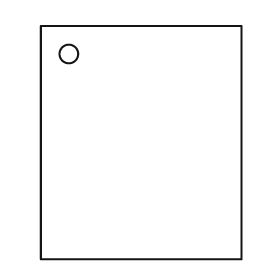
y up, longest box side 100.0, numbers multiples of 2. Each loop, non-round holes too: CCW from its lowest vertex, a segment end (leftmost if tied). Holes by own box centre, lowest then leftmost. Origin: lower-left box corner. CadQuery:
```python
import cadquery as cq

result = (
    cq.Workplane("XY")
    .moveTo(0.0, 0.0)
    .lineTo(86.0, 0.0)
    .lineTo(86.0, 100.0)
    .lineTo(0.0, 100.0)
    .close()
    .moveTo(12.0, 88.0)
    .circle(4.0)
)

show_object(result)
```